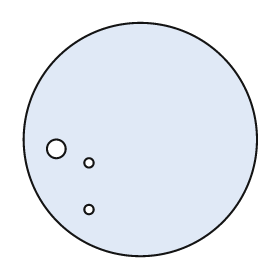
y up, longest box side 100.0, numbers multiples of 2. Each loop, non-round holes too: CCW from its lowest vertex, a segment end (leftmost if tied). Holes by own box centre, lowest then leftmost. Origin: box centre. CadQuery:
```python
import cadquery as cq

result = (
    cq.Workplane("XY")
    .moveTo(0.0, 0.0)
    .circle(50.0)
    .moveTo(-22.0, -30.0)
    .circle(2.0)
    .moveTo(-22.0, -10.0)
    .circle(2.0)
    .moveTo(-36.0, -4.0)
    .circle(4.0)
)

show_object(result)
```